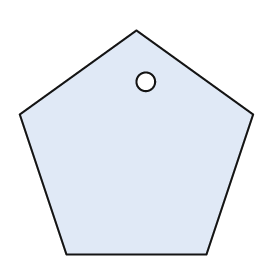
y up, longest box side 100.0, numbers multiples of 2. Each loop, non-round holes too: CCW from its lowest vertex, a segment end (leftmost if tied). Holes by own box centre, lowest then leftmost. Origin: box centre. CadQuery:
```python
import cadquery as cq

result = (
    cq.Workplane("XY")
    .moveTo(-30.0, -48.0)
    .lineTo(30.0, -48.0)
    .lineTo(50.0, 12.0)
    .lineTo(0.0, 48.0)
    .lineTo(-50.0, 12.0)
    .close()
    .moveTo(4.0, 26.0)
    .circle(4.0)
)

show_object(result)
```